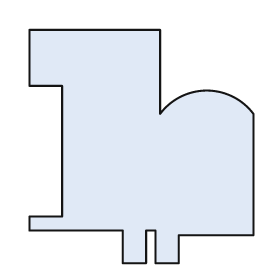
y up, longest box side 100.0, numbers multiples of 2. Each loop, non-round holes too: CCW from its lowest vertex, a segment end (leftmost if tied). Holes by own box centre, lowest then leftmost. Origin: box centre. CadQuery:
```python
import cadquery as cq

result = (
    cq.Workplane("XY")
    .moveTo(-8.0, -50.0)
    .lineTo(2.0, -50.0)
    .lineTo(2.0, -36.0)
    .lineTo(6.0, -36.0)
    .lineTo(6.0, -50.0)
    .lineTo(16.0, -50.0)
    .lineTo(16.0, -38.0)
    .lineTo(48.0, -38.0)
    .lineTo(48.0, 14.0)
    .threePointArc((28.0, 24.0), (8.0, 14.0))
    .lineTo(8.0, 50.0)
    .lineTo(-48.0, 50.0)
    .lineTo(-48.0, 26.0)
    .lineTo(-34.0, 26.0)
    .lineTo(-34.0, -30.0)
    .lineTo(-48.0, -30.0)
    .lineTo(-48.0, -36.0)
    .lineTo(-8.0, -36.0)
    .close()
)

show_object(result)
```